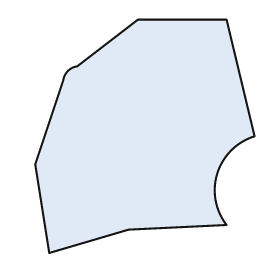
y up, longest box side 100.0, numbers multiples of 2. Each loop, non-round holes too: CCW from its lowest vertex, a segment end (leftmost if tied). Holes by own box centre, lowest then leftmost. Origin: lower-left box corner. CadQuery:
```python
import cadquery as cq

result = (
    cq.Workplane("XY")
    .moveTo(6.0, 0.0)
    .lineTo(40.0, 10.0)
    .lineTo(82.0, 12.0)
    .threePointArc((78.0, 34.0), (94.0, 50.0))
    .lineTo(82.0, 100.0)
    .lineTo(44.0, 100.0)
    .lineTo(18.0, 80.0)
    .threePointArc((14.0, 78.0), (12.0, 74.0))
    .lineTo(0.0, 38.0)
    .close()
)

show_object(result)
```